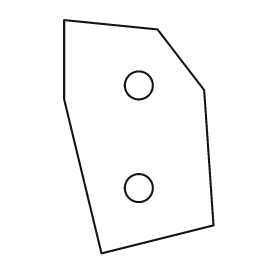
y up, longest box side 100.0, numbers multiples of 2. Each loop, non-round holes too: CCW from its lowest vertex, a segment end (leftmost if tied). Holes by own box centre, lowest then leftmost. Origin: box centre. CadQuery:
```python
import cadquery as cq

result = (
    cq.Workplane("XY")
    .moveTo(-16.0, -50.0)
    .lineTo(32.0, -38.0)
    .lineTo(28.0, 20.0)
    .lineTo(8.0, 46.0)
    .lineTo(-32.0, 50.0)
    .lineTo(-32.0, 16.0)
    .close()
    .moveTo(0.0, -22.0)
    .circle(6.0)
    .moveTo(0.0, 22.0)
    .circle(6.0)
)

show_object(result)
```